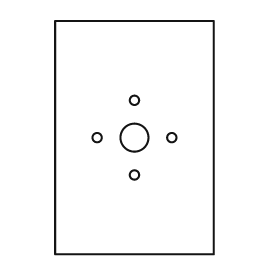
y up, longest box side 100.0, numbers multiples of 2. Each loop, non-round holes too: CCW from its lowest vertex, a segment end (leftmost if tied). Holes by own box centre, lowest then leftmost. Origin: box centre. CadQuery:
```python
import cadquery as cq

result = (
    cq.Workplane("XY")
    .moveTo(-34.0, -50.0)
    .lineTo(34.0, -50.0)
    .lineTo(34.0, 50.0)
    .lineTo(-34.0, 50.0)
    .close()
    .moveTo(0.0, -16.0)
    .circle(2.0)
    .moveTo(-16.0, 0.0)
    .circle(2.0)
    .moveTo(0.0, 0.0)
    .circle(6.0)
    .moveTo(16.0, 0.0)
    .circle(2.0)
    .moveTo(0.0, 16.0)
    .circle(2.0)
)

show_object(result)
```